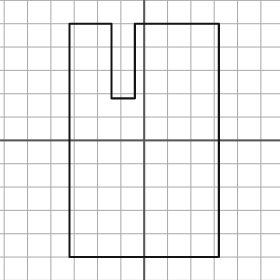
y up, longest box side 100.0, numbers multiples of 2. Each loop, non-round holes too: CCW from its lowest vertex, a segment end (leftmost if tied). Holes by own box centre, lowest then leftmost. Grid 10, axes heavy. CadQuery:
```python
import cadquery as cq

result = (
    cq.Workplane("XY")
    .moveTo(-32.0, -50.0)
    .lineTo(32.0, -50.0)
    .lineTo(32.0, 50.0)
    .lineTo(-4.0, 50.0)
    .lineTo(-4.0, 18.0)
    .lineTo(-14.0, 18.0)
    .lineTo(-14.0, 50.0)
    .lineTo(-32.0, 50.0)
    .close()
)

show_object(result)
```